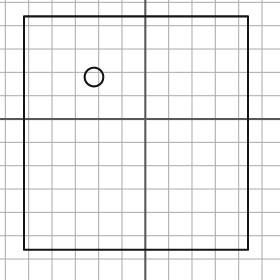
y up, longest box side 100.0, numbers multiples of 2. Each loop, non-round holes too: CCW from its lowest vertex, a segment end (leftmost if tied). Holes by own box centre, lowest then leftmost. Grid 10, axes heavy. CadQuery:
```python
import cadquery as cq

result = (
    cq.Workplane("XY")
    .moveTo(-52.0, -56.0)
    .lineTo(44.0, -56.0)
    .lineTo(44.0, 44.0)
    .lineTo(-52.0, 44.0)
    .close()
    .moveTo(-22.0, 18.0)
    .circle(4.0)
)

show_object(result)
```